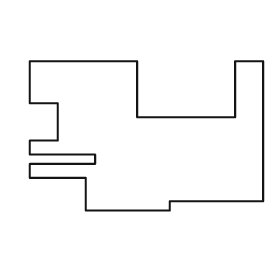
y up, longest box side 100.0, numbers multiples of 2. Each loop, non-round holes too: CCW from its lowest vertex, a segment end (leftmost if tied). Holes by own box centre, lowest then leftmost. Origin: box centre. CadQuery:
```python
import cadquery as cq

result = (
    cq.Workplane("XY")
    .moveTo(-26.0, -32.0)
    .lineTo(10.0, -32.0)
    .lineTo(10.0, -28.0)
    .lineTo(50.0, -28.0)
    .lineTo(50.0, 32.0)
    .lineTo(38.0, 32.0)
    .lineTo(38.0, 8.0)
    .lineTo(-4.0, 8.0)
    .lineTo(-4.0, 32.0)
    .lineTo(-50.0, 32.0)
    .lineTo(-50.0, 14.0)
    .lineTo(-38.0, 14.0)
    .lineTo(-38.0, -2.0)
    .lineTo(-50.0, -2.0)
    .lineTo(-50.0, -8.0)
    .lineTo(-22.0, -8.0)
    .lineTo(-22.0, -12.0)
    .lineTo(-50.0, -12.0)
    .lineTo(-50.0, -18.0)
    .lineTo(-26.0, -18.0)
    .close()
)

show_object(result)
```